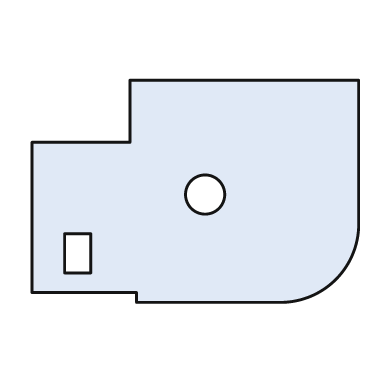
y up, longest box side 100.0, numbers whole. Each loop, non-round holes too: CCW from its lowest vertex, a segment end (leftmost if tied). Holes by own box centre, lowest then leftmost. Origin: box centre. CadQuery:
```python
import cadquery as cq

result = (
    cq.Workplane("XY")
    .moveTo(-18.0, -34.0)
    .lineTo(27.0, -34.0)
    .threePointArc((43.0, -27.0), (50.0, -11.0))
    .lineTo(50.0, 34.0)
    .lineTo(-20.0, 34.0)
    .lineTo(-20.0, 15.0)
    .lineTo(-50.0, 15.0)
    .lineTo(-50.0, -31.0)
    .lineTo(-18.0, -31.0)
    .close()
    .moveTo(-40.0, -25.0)
    .lineTo(-32.0, -25.0)
    .lineTo(-32.0, -13.0)
    .lineTo(-40.0, -13.0)
    .close()
    .moveTo(3.0, -1.0)
    .circle(6.0)
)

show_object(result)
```